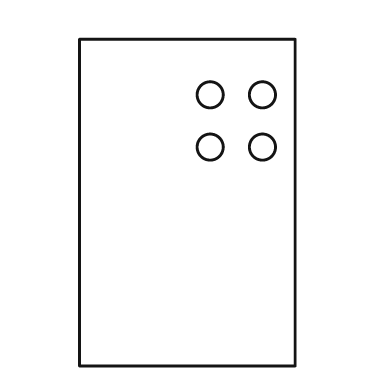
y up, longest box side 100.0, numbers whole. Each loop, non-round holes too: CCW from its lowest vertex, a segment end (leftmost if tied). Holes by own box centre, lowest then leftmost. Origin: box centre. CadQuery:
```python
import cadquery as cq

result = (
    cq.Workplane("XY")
    .moveTo(-33.0, -50.0)
    .lineTo(33.0, -50.0)
    .lineTo(33.0, 50.0)
    .lineTo(-33.0, 50.0)
    .close()
    .moveTo(7.0, 17.0)
    .circle(4.0)
    .moveTo(23.0, 17.0)
    .circle(4.0)
    .moveTo(7.0, 33.0)
    .circle(4.0)
    .moveTo(23.0, 33.0)
    .circle(4.0)
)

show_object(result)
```